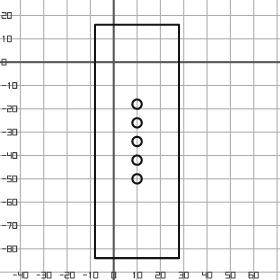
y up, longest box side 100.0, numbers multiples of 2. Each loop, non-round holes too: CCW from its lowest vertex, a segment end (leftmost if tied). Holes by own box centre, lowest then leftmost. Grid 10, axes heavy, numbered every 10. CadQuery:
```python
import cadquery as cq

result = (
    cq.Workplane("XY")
    .moveTo(-8.0, -84.0)
    .lineTo(28.0, -84.0)
    .lineTo(28.0, 16.0)
    .lineTo(-8.0, 16.0)
    .close()
    .moveTo(10.0, -50.0)
    .circle(2.0)
    .moveTo(10.0, -42.0)
    .circle(2.0)
    .moveTo(10.0, -34.0)
    .circle(2.0)
    .moveTo(10.0, -26.0)
    .circle(2.0)
    .moveTo(10.0, -18.0)
    .circle(2.0)
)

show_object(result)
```